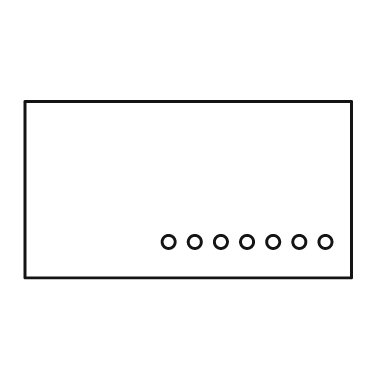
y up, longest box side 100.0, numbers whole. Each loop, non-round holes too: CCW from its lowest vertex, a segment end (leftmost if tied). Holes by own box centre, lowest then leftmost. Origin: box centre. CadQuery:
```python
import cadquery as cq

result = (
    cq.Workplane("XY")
    .moveTo(-50.0, -27.0)
    .lineTo(50.0, -27.0)
    .lineTo(50.0, 27.0)
    .lineTo(-50.0, 27.0)
    .close()
    .moveTo(-6.0, -16.0)
    .circle(2.0)
    .moveTo(2.0, -16.0)
    .circle(2.0)
    .moveTo(10.0, -16.0)
    .circle(2.0)
    .moveTo(18.0, -16.0)
    .circle(2.0)
    .moveTo(26.0, -16.0)
    .circle(2.0)
    .moveTo(34.0, -16.0)
    .circle(2.0)
    .moveTo(42.0, -16.0)
    .circle(2.0)
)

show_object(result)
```